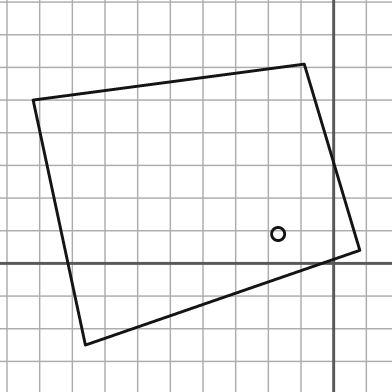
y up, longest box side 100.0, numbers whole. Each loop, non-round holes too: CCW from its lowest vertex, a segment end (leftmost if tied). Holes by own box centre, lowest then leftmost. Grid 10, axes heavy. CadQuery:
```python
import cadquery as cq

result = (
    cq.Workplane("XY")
    .moveTo(-76.0, -25.0)
    .lineTo(8.0, 4.0)
    .lineTo(-9.0, 61.0)
    .lineTo(-92.0, 50.0)
    .close()
    .moveTo(-17.0, 9.0)
    .circle(2.0)
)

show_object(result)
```